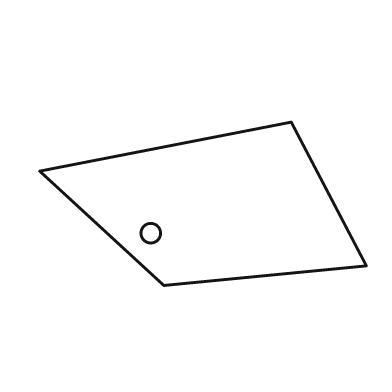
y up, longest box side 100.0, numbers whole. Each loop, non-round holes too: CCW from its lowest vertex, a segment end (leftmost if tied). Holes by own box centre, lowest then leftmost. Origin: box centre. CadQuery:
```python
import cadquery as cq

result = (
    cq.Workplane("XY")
    .moveTo(-12.0, -25.0)
    .lineTo(50.0, -19.0)
    .lineTo(27.0, 25.0)
    .lineTo(-50.0, 10.0)
    .close()
    .moveTo(-16.0, -9.0)
    .circle(3.0)
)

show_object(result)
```